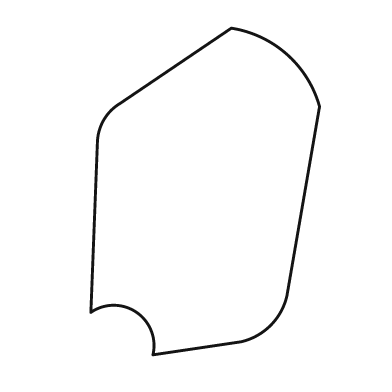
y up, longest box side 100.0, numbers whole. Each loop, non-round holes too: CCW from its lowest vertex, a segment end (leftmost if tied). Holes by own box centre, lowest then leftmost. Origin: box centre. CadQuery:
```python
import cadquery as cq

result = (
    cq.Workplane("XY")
    .moveTo(-16.0, -50.0)
    .lineTo(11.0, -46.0)
    .threePointArc((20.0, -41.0), (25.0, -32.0))
    .lineTo(35.0, 26.0)
    .threePointArc((25.0, 42.0), (8.0, 50.0))
    .lineTo(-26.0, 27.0)
    .threePointArc((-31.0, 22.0), (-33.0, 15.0))
    .lineTo(-35.0, -37.0)
    .threePointArc((-21.0, -37.0), (-16.0, -50.0))
    .close()
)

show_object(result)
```